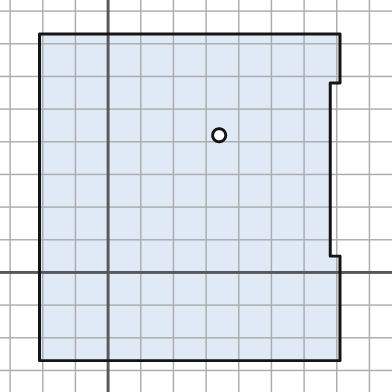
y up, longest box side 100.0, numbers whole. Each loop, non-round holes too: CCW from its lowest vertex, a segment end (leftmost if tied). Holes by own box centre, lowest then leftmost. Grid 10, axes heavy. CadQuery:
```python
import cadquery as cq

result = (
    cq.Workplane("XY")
    .moveTo(-21.0, -27.0)
    .lineTo(71.0, -27.0)
    .lineTo(71.0, 5.0)
    .lineTo(68.0, 5.0)
    .lineTo(68.0, 58.0)
    .lineTo(71.0, 58.0)
    .lineTo(71.0, 73.0)
    .lineTo(-21.0, 73.0)
    .close()
    .moveTo(34.0, 42.0)
    .circle(2.0)
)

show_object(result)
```